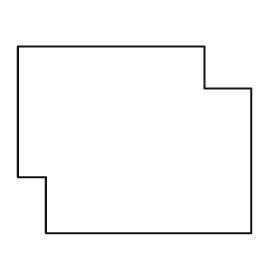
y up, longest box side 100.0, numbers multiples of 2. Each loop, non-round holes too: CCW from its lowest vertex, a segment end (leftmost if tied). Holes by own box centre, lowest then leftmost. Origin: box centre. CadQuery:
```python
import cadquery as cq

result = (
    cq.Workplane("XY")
    .moveTo(-38.0, -40.0)
    .lineTo(50.0, -40.0)
    .lineTo(50.0, 22.0)
    .lineTo(30.0, 22.0)
    .lineTo(30.0, 40.0)
    .lineTo(-50.0, 40.0)
    .lineTo(-50.0, -16.0)
    .lineTo(-38.0, -16.0)
    .close()
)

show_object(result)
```